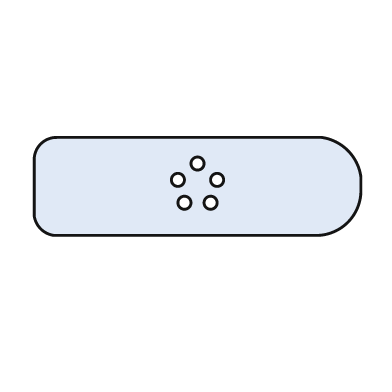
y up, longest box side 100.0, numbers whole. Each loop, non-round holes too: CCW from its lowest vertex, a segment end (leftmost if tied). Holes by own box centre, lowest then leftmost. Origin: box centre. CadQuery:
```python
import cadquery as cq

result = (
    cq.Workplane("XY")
    .moveTo(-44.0, -15.0)
    .lineTo(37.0, -15.0)
    .threePointArc((46.0, -11.0), (50.0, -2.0))
    .lineTo(50.0, 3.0)
    .threePointArc((46.0, 11.0), (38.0, 15.0))
    .lineTo(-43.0, 15.0)
    .threePointArc((-48.0, 13.0), (-50.0, 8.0))
    .lineTo(-50.0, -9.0)
    .threePointArc((-48.0, -13.0), (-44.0, -15.0))
    .close()
    .moveTo(-4.0, -5.0)
    .circle(2.0)
    .moveTo(4.0, -5.0)
    .circle(2.0)
    .moveTo(-6.0, 2.0)
    .circle(2.0)
    .moveTo(6.0, 2.0)
    .circle(2.0)
    .moveTo(0.0, 7.0)
    .circle(2.0)
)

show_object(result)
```